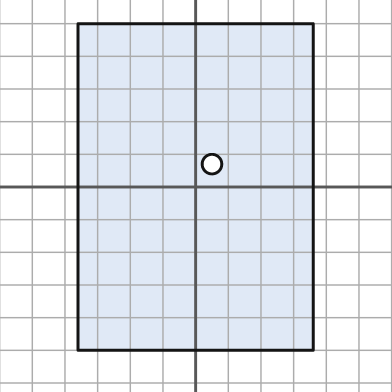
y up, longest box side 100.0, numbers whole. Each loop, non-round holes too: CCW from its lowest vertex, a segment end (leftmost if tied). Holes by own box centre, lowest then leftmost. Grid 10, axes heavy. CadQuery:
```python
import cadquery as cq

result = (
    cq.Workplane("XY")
    .moveTo(-36.0, -50.0)
    .lineTo(36.0, -50.0)
    .lineTo(36.0, 50.0)
    .lineTo(-36.0, 50.0)
    .close()
    .moveTo(5.0, 7.0)
    .circle(3.0)
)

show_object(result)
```